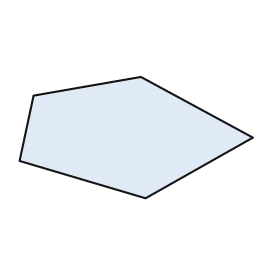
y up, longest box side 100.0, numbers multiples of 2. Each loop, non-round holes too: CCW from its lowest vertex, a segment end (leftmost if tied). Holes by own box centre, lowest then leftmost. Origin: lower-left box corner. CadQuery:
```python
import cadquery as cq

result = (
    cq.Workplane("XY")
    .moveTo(54.0, 0.0)
    .lineTo(100.0, 26.0)
    .lineTo(52.0, 52.0)
    .lineTo(6.0, 44.0)
    .lineTo(0.0, 16.0)
    .close()
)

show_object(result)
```